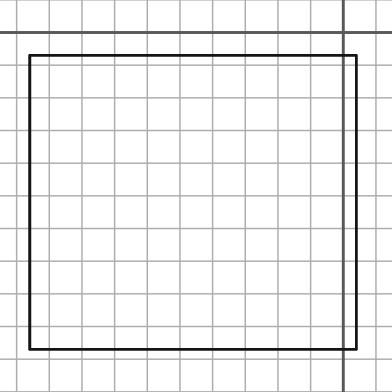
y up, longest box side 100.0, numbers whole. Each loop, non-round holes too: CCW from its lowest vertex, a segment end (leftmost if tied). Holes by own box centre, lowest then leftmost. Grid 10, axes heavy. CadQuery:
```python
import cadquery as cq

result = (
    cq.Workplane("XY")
    .moveTo(-96.0, -97.0)
    .lineTo(4.0, -97.0)
    .lineTo(4.0, -7.0)
    .lineTo(-96.0, -7.0)
    .close()
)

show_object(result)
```